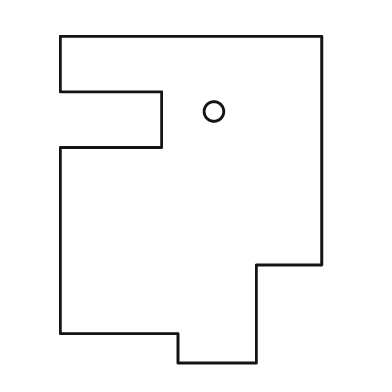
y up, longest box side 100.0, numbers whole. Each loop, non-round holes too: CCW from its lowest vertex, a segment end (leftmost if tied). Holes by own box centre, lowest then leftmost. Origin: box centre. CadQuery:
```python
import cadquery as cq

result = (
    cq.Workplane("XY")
    .moveTo(-4.0, -50.0)
    .lineTo(20.0, -50.0)
    .lineTo(20.0, -20.0)
    .lineTo(40.0, -20.0)
    .lineTo(40.0, 50.0)
    .lineTo(-40.0, 50.0)
    .lineTo(-40.0, 33.0)
    .lineTo(-9.0, 33.0)
    .lineTo(-9.0, 16.0)
    .lineTo(-40.0, 16.0)
    .lineTo(-40.0, -41.0)
    .lineTo(-4.0, -41.0)
    .close()
    .moveTo(7.0, 27.0)
    .circle(3.0)
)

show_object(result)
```